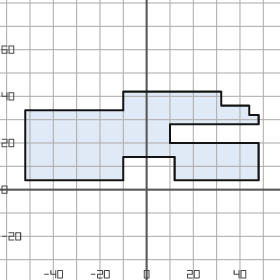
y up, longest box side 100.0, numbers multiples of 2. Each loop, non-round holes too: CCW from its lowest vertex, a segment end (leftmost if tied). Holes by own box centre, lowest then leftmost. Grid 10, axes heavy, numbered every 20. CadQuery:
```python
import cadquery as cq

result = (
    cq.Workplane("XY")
    .moveTo(-52.0, 4.0)
    .lineTo(-10.0, 4.0)
    .lineTo(-10.0, 14.0)
    .lineTo(12.0, 14.0)
    .lineTo(12.0, 4.0)
    .lineTo(48.0, 4.0)
    .lineTo(48.0, 20.0)
    .lineTo(10.0, 20.0)
    .lineTo(10.0, 28.0)
    .lineTo(48.0, 28.0)
    .lineTo(48.0, 32.0)
    .lineTo(44.0, 32.0)
    .lineTo(44.0, 36.0)
    .lineTo(32.0, 36.0)
    .lineTo(32.0, 42.0)
    .lineTo(-10.0, 42.0)
    .lineTo(-10.0, 34.0)
    .lineTo(-52.0, 34.0)
    .close()
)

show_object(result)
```